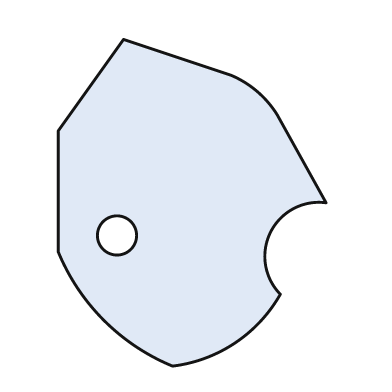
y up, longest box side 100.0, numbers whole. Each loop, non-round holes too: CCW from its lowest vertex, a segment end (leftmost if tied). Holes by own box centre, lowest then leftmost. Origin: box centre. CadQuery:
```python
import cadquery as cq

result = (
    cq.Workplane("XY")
    .moveTo(-6.0, -50.0)
    .threePointArc((13.0, -43.0), (27.0, -28.0))
    .threePointArc((24.0, -9.0), (41.0, 0.0))
    .lineTo(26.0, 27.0)
    .threePointArc((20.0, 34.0), (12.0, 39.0))
    .lineTo(-21.0, 50.0)
    .lineTo(-41.0, 22.0)
    .lineTo(-41.0, -15.0)
    .threePointArc((-27.0, -36.0), (-6.0, -50.0))
    .close()
    .moveTo(-23.0, -10.0)
    .circle(6.0)
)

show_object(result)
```